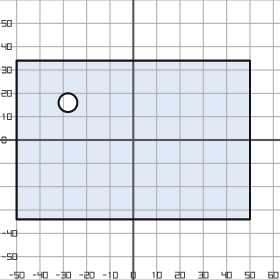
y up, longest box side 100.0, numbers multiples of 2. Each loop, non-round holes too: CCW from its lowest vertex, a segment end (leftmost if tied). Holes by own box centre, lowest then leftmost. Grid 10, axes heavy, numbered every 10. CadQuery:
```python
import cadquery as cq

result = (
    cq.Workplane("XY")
    .moveTo(-50.0, -34.0)
    .lineTo(50.0, -34.0)
    .lineTo(50.0, 34.0)
    .lineTo(-50.0, 34.0)
    .close()
    .moveTo(-28.0, 16.0)
    .circle(4.0)
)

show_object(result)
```